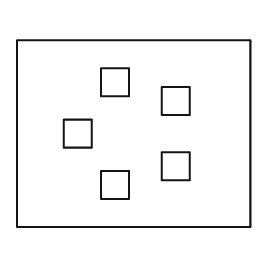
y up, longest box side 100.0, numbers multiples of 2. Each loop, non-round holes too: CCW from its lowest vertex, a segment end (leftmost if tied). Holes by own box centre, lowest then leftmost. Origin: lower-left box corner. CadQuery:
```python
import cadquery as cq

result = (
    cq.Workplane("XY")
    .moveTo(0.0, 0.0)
    .lineTo(100.0, 0.0)
    .lineTo(100.0, 80.0)
    .lineTo(0.0, 80.0)
    .close()
    .moveTo(36.0, 12.0)
    .lineTo(48.0, 12.0)
    .lineTo(48.0, 24.0)
    .lineTo(36.0, 24.0)
    .close()
    .moveTo(62.0, 20.0)
    .lineTo(74.0, 20.0)
    .lineTo(74.0, 32.0)
    .lineTo(62.0, 32.0)
    .close()
    .moveTo(20.0, 34.0)
    .lineTo(32.0, 34.0)
    .lineTo(32.0, 46.0)
    .lineTo(20.0, 46.0)
    .close()
    .moveTo(62.0, 48.0)
    .lineTo(74.0, 48.0)
    .lineTo(74.0, 60.0)
    .lineTo(62.0, 60.0)
    .close()
    .moveTo(36.0, 56.0)
    .lineTo(48.0, 56.0)
    .lineTo(48.0, 68.0)
    .lineTo(36.0, 68.0)
    .close()
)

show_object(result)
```